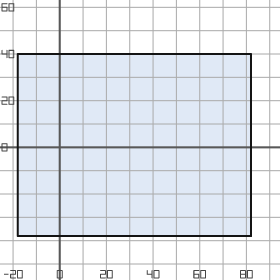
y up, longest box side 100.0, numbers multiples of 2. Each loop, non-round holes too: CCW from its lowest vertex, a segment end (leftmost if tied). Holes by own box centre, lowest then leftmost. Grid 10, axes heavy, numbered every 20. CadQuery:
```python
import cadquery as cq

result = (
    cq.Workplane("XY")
    .moveTo(-18.0, -38.0)
    .lineTo(82.0, -38.0)
    .lineTo(82.0, 40.0)
    .lineTo(-18.0, 40.0)
    .close()
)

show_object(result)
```